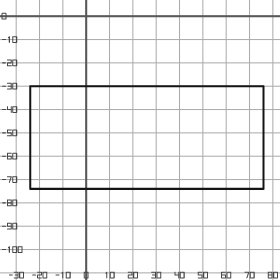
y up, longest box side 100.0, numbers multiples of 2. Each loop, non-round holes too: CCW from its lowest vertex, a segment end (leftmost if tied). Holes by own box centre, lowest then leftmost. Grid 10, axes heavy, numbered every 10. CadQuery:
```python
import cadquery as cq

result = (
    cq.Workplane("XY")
    .moveTo(-24.0, -74.0)
    .lineTo(76.0, -74.0)
    .lineTo(76.0, -30.0)
    .lineTo(-24.0, -30.0)
    .close()
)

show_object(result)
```